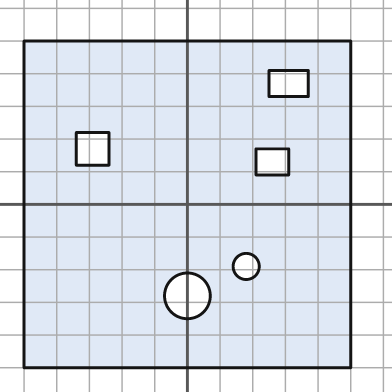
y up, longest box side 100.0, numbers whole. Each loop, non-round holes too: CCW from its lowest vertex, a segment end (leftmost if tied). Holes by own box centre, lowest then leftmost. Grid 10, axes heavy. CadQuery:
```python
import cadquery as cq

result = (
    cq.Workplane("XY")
    .moveTo(-50.0, -50.0)
    .lineTo(50.0, -50.0)
    .lineTo(50.0, 50.0)
    .lineTo(-50.0, 50.0)
    .close()
    .moveTo(0.0, -28.0)
    .circle(7.0)
    .moveTo(18.0, -19.0)
    .circle(4.0)
    .moveTo(21.0, 9.0)
    .lineTo(31.0, 9.0)
    .lineTo(31.0, 17.0)
    .lineTo(21.0, 17.0)
    .close()
    .moveTo(-34.0, 12.0)
    .lineTo(-24.0, 12.0)
    .lineTo(-24.0, 22.0)
    .lineTo(-34.0, 22.0)
    .close()
    .moveTo(25.0, 33.0)
    .lineTo(37.0, 33.0)
    .lineTo(37.0, 41.0)
    .lineTo(25.0, 41.0)
    .close()
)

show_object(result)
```